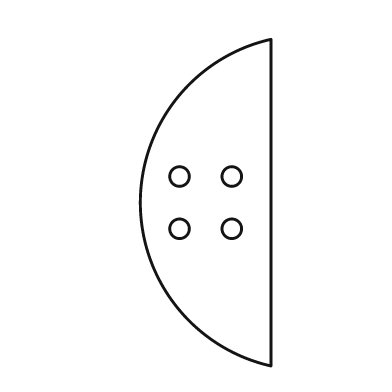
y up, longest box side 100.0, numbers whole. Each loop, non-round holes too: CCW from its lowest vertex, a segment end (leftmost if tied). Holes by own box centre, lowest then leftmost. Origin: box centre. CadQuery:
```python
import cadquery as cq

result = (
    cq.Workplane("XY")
    .moveTo(20.0, -50.0)
    .lineTo(20.0, 50.0)
    .threePointArc((-20.0, 0.0), (20.0, -50.0))
    .close()
    .moveTo(-8.0, -8.0)
    .circle(3.0)
    .moveTo(8.0, -8.0)
    .circle(3.0)
    .moveTo(-8.0, 8.0)
    .circle(3.0)
    .moveTo(8.0, 8.0)
    .circle(3.0)
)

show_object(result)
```